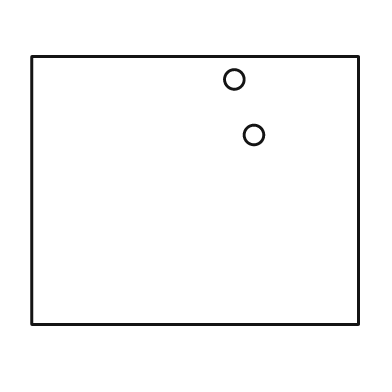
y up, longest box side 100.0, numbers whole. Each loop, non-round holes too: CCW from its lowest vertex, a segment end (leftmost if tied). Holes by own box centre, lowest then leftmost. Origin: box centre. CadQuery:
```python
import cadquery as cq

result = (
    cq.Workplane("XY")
    .moveTo(-50.0, -41.0)
    .lineTo(50.0, -41.0)
    .lineTo(50.0, 41.0)
    .lineTo(-50.0, 41.0)
    .close()
    .moveTo(18.0, 17.0)
    .circle(3.0)
    .moveTo(12.0, 34.0)
    .circle(3.0)
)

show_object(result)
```